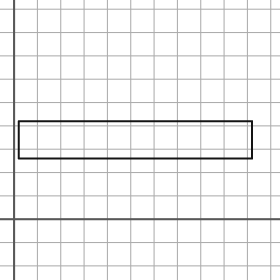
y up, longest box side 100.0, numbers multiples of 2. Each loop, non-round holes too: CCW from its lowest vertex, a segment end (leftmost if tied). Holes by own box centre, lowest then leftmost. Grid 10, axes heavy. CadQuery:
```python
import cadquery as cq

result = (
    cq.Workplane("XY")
    .moveTo(2.0, 26.0)
    .lineTo(102.0, 26.0)
    .lineTo(102.0, 42.0)
    .lineTo(2.0, 42.0)
    .close()
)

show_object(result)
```